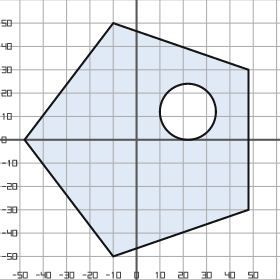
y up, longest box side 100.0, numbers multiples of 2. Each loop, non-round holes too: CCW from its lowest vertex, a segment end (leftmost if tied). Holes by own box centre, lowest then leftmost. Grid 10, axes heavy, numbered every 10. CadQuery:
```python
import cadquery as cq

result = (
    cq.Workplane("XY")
    .moveTo(-10.0, -50.0)
    .lineTo(48.0, -30.0)
    .lineTo(48.0, 30.0)
    .lineTo(-10.0, 50.0)
    .lineTo(-48.0, 0.0)
    .close()
    .moveTo(22.0, 12.0)
    .circle(12.0)
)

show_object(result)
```